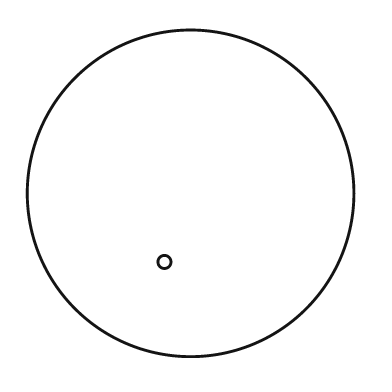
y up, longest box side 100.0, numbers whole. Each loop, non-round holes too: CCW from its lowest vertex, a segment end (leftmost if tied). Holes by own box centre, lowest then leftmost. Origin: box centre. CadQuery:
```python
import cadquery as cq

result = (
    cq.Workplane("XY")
    .moveTo(0.0, 0.0)
    .circle(50.0)
    .moveTo(-8.0, -21.0)
    .circle(2.0)
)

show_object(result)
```